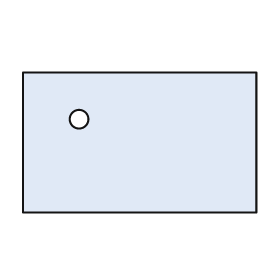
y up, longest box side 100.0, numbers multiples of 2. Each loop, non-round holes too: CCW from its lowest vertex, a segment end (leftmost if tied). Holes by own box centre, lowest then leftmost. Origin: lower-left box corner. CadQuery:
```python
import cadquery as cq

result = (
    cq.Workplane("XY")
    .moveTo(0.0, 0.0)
    .lineTo(100.0, 0.0)
    .lineTo(100.0, 60.0)
    .lineTo(0.0, 60.0)
    .close()
    .moveTo(24.0, 40.0)
    .circle(4.0)
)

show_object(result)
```